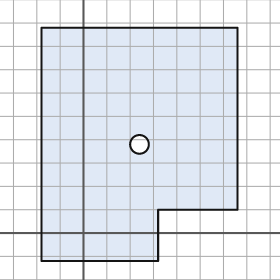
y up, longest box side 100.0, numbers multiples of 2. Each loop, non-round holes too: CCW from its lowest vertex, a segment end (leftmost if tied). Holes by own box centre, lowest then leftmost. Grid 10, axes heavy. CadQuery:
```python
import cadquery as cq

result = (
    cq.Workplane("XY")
    .moveTo(-18.0, -12.0)
    .lineTo(32.0, -12.0)
    .lineTo(32.0, 10.0)
    .lineTo(66.0, 10.0)
    .lineTo(66.0, 88.0)
    .lineTo(-18.0, 88.0)
    .close()
    .moveTo(24.0, 38.0)
    .circle(4.0)
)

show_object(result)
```